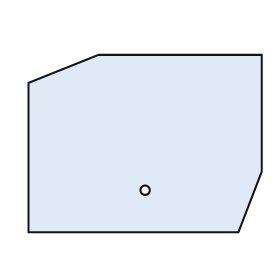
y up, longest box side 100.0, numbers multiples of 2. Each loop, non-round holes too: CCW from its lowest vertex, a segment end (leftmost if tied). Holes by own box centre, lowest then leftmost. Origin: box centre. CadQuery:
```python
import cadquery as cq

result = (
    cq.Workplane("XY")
    .moveTo(-50.0, -38.0)
    .lineTo(40.0, -38.0)
    .lineTo(50.0, -12.0)
    .lineTo(50.0, 38.0)
    .lineTo(-20.0, 38.0)
    .lineTo(-50.0, 26.0)
    .close()
    .moveTo(0.0, -20.0)
    .circle(2.0)
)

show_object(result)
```